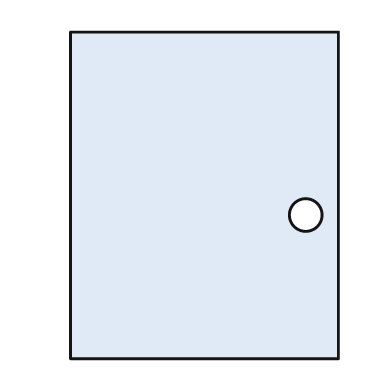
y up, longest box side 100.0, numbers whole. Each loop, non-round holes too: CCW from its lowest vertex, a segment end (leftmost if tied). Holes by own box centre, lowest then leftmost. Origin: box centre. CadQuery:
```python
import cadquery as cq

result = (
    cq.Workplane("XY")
    .moveTo(-41.0, -50.0)
    .lineTo(41.0, -50.0)
    .lineTo(41.0, 50.0)
    .lineTo(-41.0, 50.0)
    .close()
    .moveTo(31.0, -6.0)
    .circle(5.0)
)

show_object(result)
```